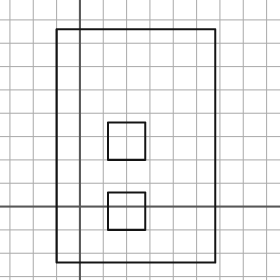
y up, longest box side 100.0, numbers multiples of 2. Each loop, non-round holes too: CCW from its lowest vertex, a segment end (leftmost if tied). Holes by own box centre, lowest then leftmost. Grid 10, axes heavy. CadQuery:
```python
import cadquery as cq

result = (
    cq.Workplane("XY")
    .moveTo(-10.0, -24.0)
    .lineTo(58.0, -24.0)
    .lineTo(58.0, 76.0)
    .lineTo(-10.0, 76.0)
    .close()
    .moveTo(12.0, -10.0)
    .lineTo(28.0, -10.0)
    .lineTo(28.0, 6.0)
    .lineTo(12.0, 6.0)
    .close()
    .moveTo(12.0, 20.0)
    .lineTo(28.0, 20.0)
    .lineTo(28.0, 36.0)
    .lineTo(12.0, 36.0)
    .close()
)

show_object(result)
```